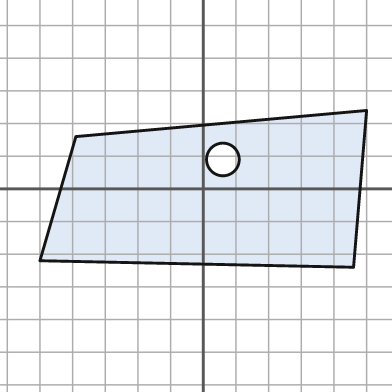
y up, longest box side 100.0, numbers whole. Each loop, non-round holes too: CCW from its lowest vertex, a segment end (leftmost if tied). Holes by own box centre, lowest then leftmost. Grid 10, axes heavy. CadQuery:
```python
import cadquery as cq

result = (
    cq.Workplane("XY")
    .moveTo(46.0, -24.0)
    .lineTo(50.0, 24.0)
    .lineTo(-39.0, 16.0)
    .lineTo(-50.0, -22.0)
    .close()
    .moveTo(6.0, 9.0)
    .circle(5.0)
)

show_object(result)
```